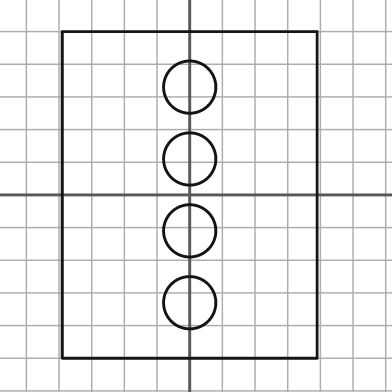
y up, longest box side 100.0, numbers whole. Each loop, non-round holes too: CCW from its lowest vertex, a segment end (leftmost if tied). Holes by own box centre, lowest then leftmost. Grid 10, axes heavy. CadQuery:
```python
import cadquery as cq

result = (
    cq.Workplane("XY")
    .moveTo(-39.0, -50.0)
    .lineTo(39.0, -50.0)
    .lineTo(39.0, 50.0)
    .lineTo(-39.0, 50.0)
    .close()
    .moveTo(0.0, -33.0)
    .circle(8.0)
    .moveTo(0.0, -11.0)
    .circle(8.0)
    .moveTo(0.0, 11.0)
    .circle(8.0)
    .moveTo(0.0, 33.0)
    .circle(8.0)
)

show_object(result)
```